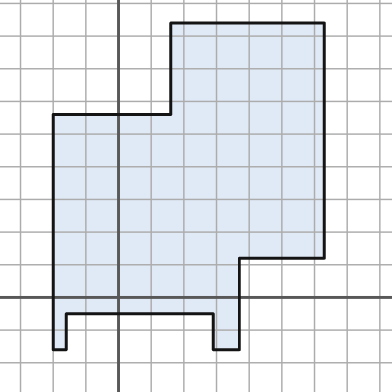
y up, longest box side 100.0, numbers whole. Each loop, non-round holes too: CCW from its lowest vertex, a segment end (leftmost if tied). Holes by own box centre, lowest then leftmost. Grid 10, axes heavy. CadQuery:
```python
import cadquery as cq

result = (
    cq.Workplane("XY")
    .moveTo(-20.0, -16.0)
    .lineTo(-16.0, -16.0)
    .lineTo(-16.0, -5.0)
    .lineTo(29.0, -5.0)
    .lineTo(29.0, -16.0)
    .lineTo(37.0, -16.0)
    .lineTo(37.0, 12.0)
    .lineTo(63.0, 12.0)
    .lineTo(63.0, 84.0)
    .lineTo(16.0, 84.0)
    .lineTo(16.0, 56.0)
    .lineTo(-20.0, 56.0)
    .close()
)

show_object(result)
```